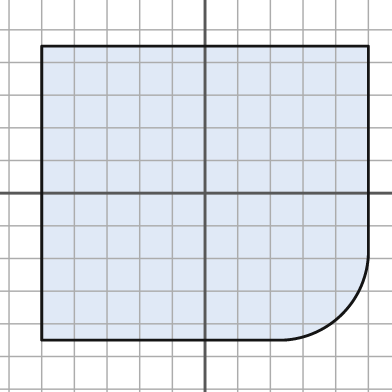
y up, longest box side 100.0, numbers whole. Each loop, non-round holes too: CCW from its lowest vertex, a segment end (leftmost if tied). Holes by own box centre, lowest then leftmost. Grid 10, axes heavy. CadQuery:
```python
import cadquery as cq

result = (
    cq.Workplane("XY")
    .moveTo(-50.0, -45.0)
    .lineTo(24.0, -45.0)
    .threePointArc((42.0, -37.0), (50.0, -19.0))
    .lineTo(50.0, 45.0)
    .lineTo(-50.0, 45.0)
    .close()
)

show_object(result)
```